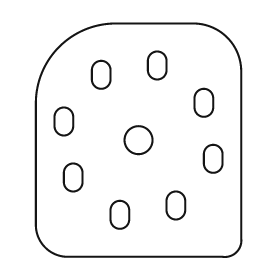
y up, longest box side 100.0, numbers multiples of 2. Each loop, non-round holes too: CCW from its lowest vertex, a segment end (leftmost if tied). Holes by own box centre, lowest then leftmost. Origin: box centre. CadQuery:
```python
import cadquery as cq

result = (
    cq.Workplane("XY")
    .moveTo(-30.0, -50.0)
    .lineTo(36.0, -50.0)
    .threePointArc((42.0, -48.0), (44.0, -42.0))
    .lineTo(44.0, 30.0)
    .threePointArc((38.0, 44.0), (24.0, 50.0))
    .lineTo(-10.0, 50.0)
    .threePointArc((-34.0, 40.0), (-44.0, 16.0))
    .lineTo(-44.0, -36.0)
    .threePointArc((-40.0, -46.0), (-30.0, -50.0))
    .close()
    .moveTo(-12.0, -34.0)
    .threePointArc((-8.0, -38.0), (-4.0, -34.0))
    .lineTo(-4.0, -30.0)
    .threePointArc((-8.0, -26.0), (-12.0, -30.0))
    .close()
    .moveTo(12.0, -30.0)
    .threePointArc((16.0, -34.0), (20.0, -30.0))
    .lineTo(20.0, -26.0)
    .threePointArc((16.0, -22.0), (12.0, -26.0))
    .close()
    .moveTo(-32.0, -18.0)
    .threePointArc((-28.0, -22.0), (-24.0, -18.0))
    .lineTo(-24.0, -14.0)
    .threePointArc((-28.0, -10.0), (-32.0, -14.0))
    .close()
    .moveTo(28.0, -10.0)
    .threePointArc((32.0, -14.0), (36.0, -10.0))
    .lineTo(36.0, -6.0)
    .threePointArc((32.0, -2.0), (28.0, -6.0))
    .close()
    .moveTo(0.0, 0.0)
    .circle(6.0)
    .moveTo(-36.0, 6.0)
    .threePointArc((-32.0, 2.0), (-28.0, 6.0))
    .lineTo(-28.0, 10.0)
    .threePointArc((-32.0, 14.0), (-36.0, 10.0))
    .close()
    .moveTo(24.0, 14.0)
    .threePointArc((28.0, 10.0), (32.0, 14.0))
    .lineTo(32.0, 18.0)
    .threePointArc((28.0, 22.0), (24.0, 18.0))
    .close()
    .moveTo(-20.0, 26.0)
    .threePointArc((-16.0, 22.0), (-12.0, 26.0))
    .lineTo(-12.0, 30.0)
    .threePointArc((-16.0, 34.0), (-20.0, 30.0))
    .close()
    .moveTo(4.0, 30.0)
    .threePointArc((8.0, 26.0), (12.0, 30.0))
    .lineTo(12.0, 34.0)
    .threePointArc((8.0, 38.0), (4.0, 34.0))
    .close()
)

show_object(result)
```